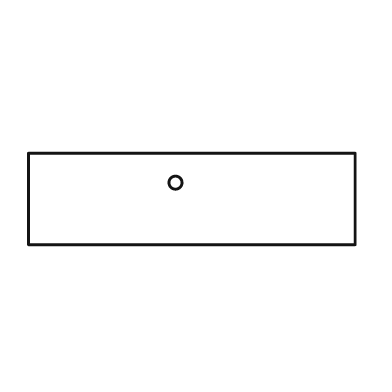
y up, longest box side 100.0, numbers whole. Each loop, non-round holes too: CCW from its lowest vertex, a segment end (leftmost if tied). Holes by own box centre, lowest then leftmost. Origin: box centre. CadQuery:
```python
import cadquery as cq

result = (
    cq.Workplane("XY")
    .moveTo(-50.0, -14.0)
    .lineTo(50.0, -14.0)
    .lineTo(50.0, 14.0)
    .lineTo(-50.0, 14.0)
    .close()
    .moveTo(-5.0, 5.0)
    .circle(2.0)
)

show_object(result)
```